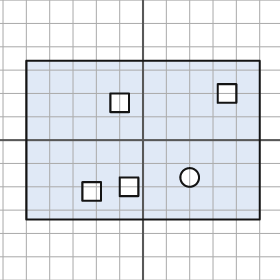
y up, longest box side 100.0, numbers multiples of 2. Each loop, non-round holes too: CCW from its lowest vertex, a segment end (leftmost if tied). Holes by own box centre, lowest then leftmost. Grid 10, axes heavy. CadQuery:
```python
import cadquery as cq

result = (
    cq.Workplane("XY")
    .moveTo(-50.0, -34.0)
    .lineTo(50.0, -34.0)
    .lineTo(50.0, 34.0)
    .lineTo(-50.0, 34.0)
    .close()
    .moveTo(-26.0, -26.0)
    .lineTo(-18.0, -26.0)
    .lineTo(-18.0, -18.0)
    .lineTo(-26.0, -18.0)
    .close()
    .moveTo(-10.0, -24.0)
    .lineTo(-2.0, -24.0)
    .lineTo(-2.0, -16.0)
    .lineTo(-10.0, -16.0)
    .close()
    .moveTo(20.0, -16.0)
    .circle(4.0)
    .moveTo(-14.0, 12.0)
    .lineTo(-6.0, 12.0)
    .lineTo(-6.0, 20.0)
    .lineTo(-14.0, 20.0)
    .close()
    .moveTo(32.0, 16.0)
    .lineTo(40.0, 16.0)
    .lineTo(40.0, 24.0)
    .lineTo(32.0, 24.0)
    .close()
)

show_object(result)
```